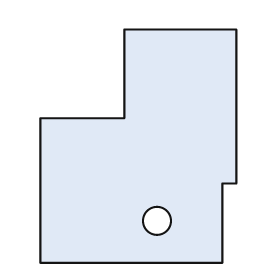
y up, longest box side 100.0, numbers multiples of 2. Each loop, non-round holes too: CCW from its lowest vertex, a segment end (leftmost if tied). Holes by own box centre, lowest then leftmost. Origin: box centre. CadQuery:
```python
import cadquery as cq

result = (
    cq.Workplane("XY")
    .moveTo(-42.0, -50.0)
    .lineTo(36.0, -50.0)
    .lineTo(36.0, -16.0)
    .lineTo(42.0, -16.0)
    .lineTo(42.0, 50.0)
    .lineTo(-6.0, 50.0)
    .lineTo(-6.0, 12.0)
    .lineTo(-42.0, 12.0)
    .close()
    .moveTo(8.0, -32.0)
    .circle(6.0)
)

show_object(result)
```